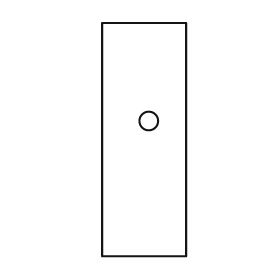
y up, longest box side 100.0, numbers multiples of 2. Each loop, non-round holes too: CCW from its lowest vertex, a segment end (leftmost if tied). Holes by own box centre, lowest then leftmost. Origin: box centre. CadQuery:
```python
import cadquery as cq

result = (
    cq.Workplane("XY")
    .moveTo(-18.0, -50.0)
    .lineTo(18.0, -50.0)
    .lineTo(18.0, 50.0)
    .lineTo(-18.0, 50.0)
    .close()
    .moveTo(2.0, 8.0)
    .circle(4.0)
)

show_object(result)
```